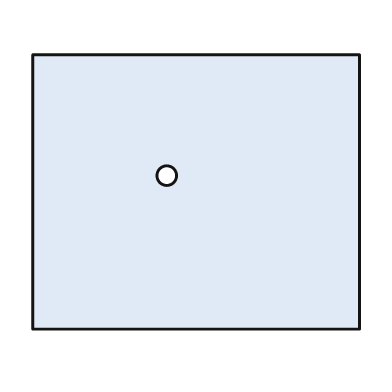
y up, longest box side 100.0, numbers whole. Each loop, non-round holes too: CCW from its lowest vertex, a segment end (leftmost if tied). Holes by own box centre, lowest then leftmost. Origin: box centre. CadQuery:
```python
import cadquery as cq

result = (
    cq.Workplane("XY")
    .moveTo(-50.0, -42.0)
    .lineTo(50.0, -42.0)
    .lineTo(50.0, 42.0)
    .lineTo(-50.0, 42.0)
    .close()
    .moveTo(-9.0, 5.0)
    .circle(3.0)
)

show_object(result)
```